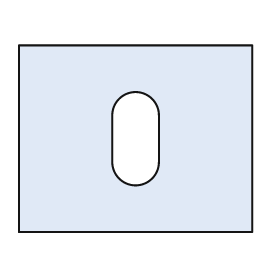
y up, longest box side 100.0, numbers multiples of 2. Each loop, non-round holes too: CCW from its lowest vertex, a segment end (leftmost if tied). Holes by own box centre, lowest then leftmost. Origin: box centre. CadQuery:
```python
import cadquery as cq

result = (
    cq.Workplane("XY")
    .moveTo(-50.0, -40.0)
    .lineTo(50.0, -40.0)
    .lineTo(50.0, 40.0)
    .lineTo(-50.0, 40.0)
    .close()
    .moveTo(-10.0, -10.0)
    .threePointArc((0.0, -20.0), (10.0, -10.0))
    .lineTo(10.0, 10.0)
    .threePointArc((0.0, 20.0), (-10.0, 10.0))
    .close()
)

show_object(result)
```